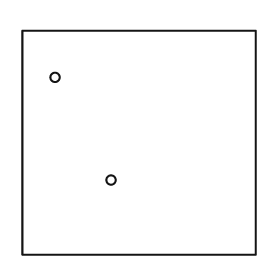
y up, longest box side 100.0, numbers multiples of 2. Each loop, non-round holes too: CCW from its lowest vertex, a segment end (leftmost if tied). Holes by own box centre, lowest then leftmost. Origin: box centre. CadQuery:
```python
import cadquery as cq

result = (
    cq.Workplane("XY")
    .moveTo(-50.0, -48.0)
    .lineTo(50.0, -48.0)
    .lineTo(50.0, 48.0)
    .lineTo(-50.0, 48.0)
    .close()
    .moveTo(-12.0, -16.0)
    .circle(2.0)
    .moveTo(-36.0, 28.0)
    .circle(2.0)
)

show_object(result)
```